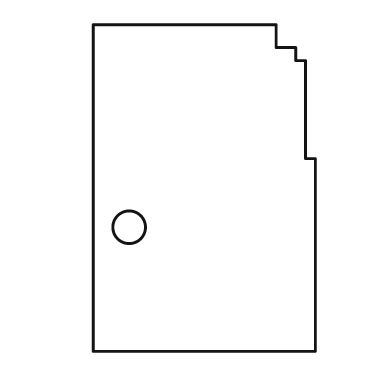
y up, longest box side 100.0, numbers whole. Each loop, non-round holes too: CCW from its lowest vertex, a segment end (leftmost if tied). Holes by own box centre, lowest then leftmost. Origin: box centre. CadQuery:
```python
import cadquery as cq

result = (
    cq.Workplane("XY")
    .moveTo(-34.0, -50.0)
    .lineTo(34.0, -50.0)
    .lineTo(34.0, 9.0)
    .lineTo(31.0, 9.0)
    .lineTo(31.0, 39.0)
    .lineTo(28.0, 39.0)
    .lineTo(28.0, 43.0)
    .lineTo(22.0, 43.0)
    .lineTo(22.0, 50.0)
    .lineTo(-34.0, 50.0)
    .close()
    .moveTo(-23.0, -12.0)
    .circle(5.0)
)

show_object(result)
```